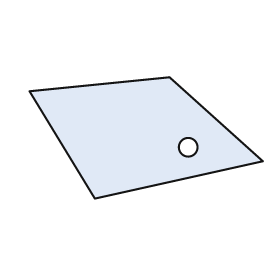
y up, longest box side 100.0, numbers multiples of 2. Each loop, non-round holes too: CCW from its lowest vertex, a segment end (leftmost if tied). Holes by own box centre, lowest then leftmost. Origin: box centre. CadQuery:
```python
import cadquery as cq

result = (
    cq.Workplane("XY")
    .moveTo(-22.0, -26.0)
    .lineTo(50.0, -10.0)
    .lineTo(10.0, 26.0)
    .lineTo(-50.0, 20.0)
    .close()
    .moveTo(18.0, -4.0)
    .circle(4.0)
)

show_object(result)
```